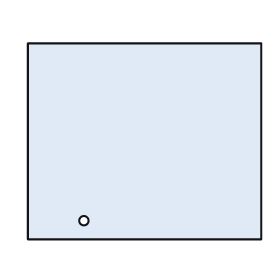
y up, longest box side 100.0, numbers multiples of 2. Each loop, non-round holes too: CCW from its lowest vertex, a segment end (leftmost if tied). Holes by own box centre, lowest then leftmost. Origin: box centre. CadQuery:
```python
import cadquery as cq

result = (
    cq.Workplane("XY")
    .moveTo(-50.0, -42.0)
    .lineTo(50.0, -42.0)
    .lineTo(50.0, 42.0)
    .lineTo(-50.0, 42.0)
    .close()
    .moveTo(-26.0, -34.0)
    .circle(2.0)
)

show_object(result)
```